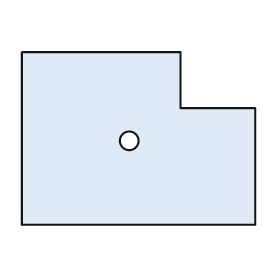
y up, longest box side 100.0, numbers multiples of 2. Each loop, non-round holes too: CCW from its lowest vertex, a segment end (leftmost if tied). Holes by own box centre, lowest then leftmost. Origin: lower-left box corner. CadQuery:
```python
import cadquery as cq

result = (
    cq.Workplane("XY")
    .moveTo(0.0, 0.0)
    .lineTo(100.0, 0.0)
    .lineTo(100.0, 50.0)
    .lineTo(68.0, 50.0)
    .lineTo(68.0, 74.0)
    .lineTo(0.0, 74.0)
    .close()
    .moveTo(46.0, 36.0)
    .circle(4.0)
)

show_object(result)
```